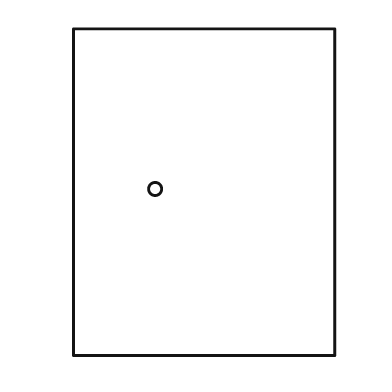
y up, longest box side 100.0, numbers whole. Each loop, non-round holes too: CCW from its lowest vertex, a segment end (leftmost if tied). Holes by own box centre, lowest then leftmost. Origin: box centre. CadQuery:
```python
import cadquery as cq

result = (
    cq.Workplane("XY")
    .moveTo(-40.0, -50.0)
    .lineTo(40.0, -50.0)
    .lineTo(40.0, 50.0)
    .lineTo(-40.0, 50.0)
    .close()
    .moveTo(-15.0, 1.0)
    .circle(2.0)
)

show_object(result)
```